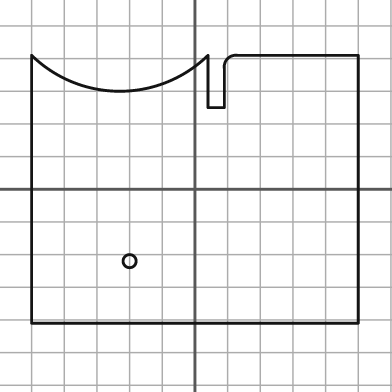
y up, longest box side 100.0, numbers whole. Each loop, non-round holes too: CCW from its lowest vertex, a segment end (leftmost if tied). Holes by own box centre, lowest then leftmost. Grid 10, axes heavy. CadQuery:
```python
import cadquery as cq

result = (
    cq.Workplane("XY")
    .moveTo(-50.0, -41.0)
    .lineTo(50.0, -41.0)
    .lineTo(50.0, 41.0)
    .lineTo(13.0, 41.0)
    .threePointArc((10.0, 40.0), (9.0, 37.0))
    .lineTo(9.0, 25.0)
    .lineTo(4.0, 25.0)
    .lineTo(4.0, 41.0)
    .threePointArc((-23.0, 30.0), (-50.0, 41.0))
    .close()
    .moveTo(-20.0, -22.0)
    .circle(2.0)
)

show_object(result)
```